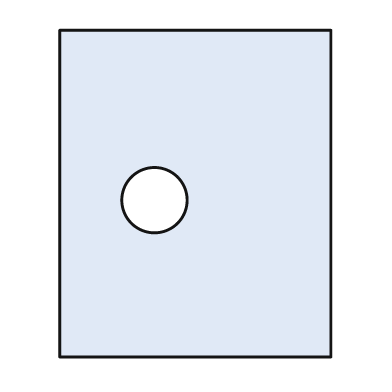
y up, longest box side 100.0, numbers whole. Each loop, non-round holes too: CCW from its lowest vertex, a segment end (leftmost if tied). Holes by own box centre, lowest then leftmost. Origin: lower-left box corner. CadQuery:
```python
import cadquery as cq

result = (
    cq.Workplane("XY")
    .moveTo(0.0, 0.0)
    .lineTo(83.0, 0.0)
    .lineTo(83.0, 100.0)
    .lineTo(0.0, 100.0)
    .close()
    .moveTo(29.0, 48.0)
    .circle(10.0)
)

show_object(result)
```